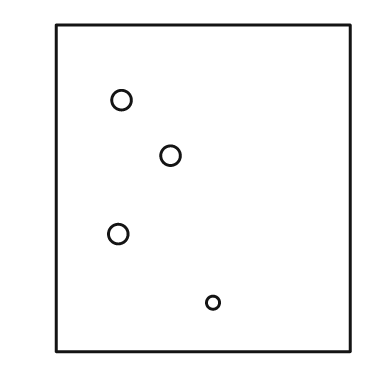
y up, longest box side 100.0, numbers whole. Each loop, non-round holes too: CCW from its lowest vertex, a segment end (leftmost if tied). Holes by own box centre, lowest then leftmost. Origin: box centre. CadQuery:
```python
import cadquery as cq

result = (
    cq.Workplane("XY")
    .moveTo(-45.0, -50.0)
    .lineTo(45.0, -50.0)
    .lineTo(45.0, 50.0)
    .lineTo(-45.0, 50.0)
    .close()
    .moveTo(3.0, -35.0)
    .circle(2.0)
    .moveTo(-26.0, -14.0)
    .circle(3.0)
    .moveTo(-10.0, 10.0)
    .circle(3.0)
    .moveTo(-25.0, 27.0)
    .circle(3.0)
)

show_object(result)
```